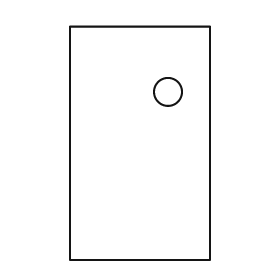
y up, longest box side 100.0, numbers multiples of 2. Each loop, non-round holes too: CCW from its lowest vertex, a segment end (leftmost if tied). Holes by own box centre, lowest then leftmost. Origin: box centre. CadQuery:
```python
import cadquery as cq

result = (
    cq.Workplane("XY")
    .moveTo(-30.0, -50.0)
    .lineTo(30.0, -50.0)
    .lineTo(30.0, 50.0)
    .lineTo(-30.0, 50.0)
    .close()
    .moveTo(12.0, 22.0)
    .circle(6.0)
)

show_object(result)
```